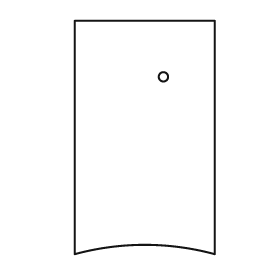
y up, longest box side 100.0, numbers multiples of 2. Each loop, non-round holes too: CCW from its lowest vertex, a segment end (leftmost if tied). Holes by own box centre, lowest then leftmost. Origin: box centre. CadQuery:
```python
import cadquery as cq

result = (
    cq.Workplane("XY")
    .moveTo(-30.0, -50.0)
    .threePointArc((0.0, -46.0), (30.0, -50.0))
    .lineTo(30.0, 50.0)
    .lineTo(-30.0, 50.0)
    .close()
    .moveTo(8.0, 26.0)
    .circle(2.0)
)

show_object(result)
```